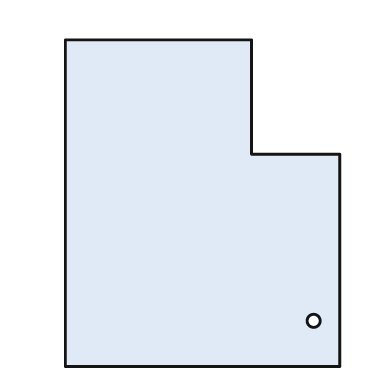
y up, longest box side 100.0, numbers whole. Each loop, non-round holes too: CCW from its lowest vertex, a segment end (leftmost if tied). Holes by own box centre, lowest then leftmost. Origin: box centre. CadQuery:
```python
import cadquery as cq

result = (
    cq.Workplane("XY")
    .moveTo(-42.0, -50.0)
    .lineTo(42.0, -50.0)
    .lineTo(42.0, 15.0)
    .lineTo(15.0, 15.0)
    .lineTo(15.0, 50.0)
    .lineTo(-42.0, 50.0)
    .close()
    .moveTo(34.0, -36.0)
    .circle(2.0)
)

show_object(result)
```